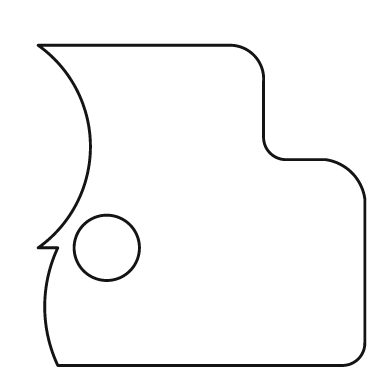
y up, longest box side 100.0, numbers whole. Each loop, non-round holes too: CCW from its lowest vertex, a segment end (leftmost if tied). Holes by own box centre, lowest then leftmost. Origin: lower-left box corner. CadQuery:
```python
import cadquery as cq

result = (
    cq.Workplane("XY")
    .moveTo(6.0, 0.0)
    .lineTo(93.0, 0.0)
    .threePointArc((98.0, 2.0), (100.0, 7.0))
    .lineTo(100.0, 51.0)
    .threePointArc((96.0, 59.0), (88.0, 63.0))
    .lineTo(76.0, 63.0)
    .threePointArc((71.0, 65.0), (69.0, 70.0))
    .lineTo(69.0, 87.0)
    .threePointArc((66.0, 95.0), (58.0, 98.0))
    .lineTo(0.0, 98.0)
    .threePointArc((16.0, 67.0), (0.0, 36.0))
    .lineTo(6.0, 36.0)
    .threePointArc((2.0, 18.0), (6.0, 0.0))
    .close()
    .moveTo(21.0, 36.0)
    .circle(10.0)
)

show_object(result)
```